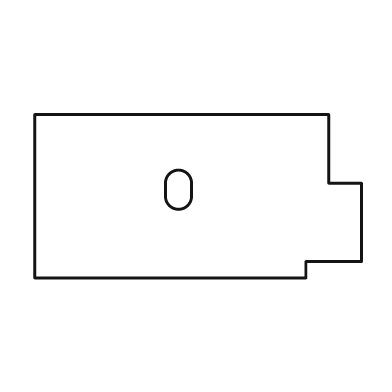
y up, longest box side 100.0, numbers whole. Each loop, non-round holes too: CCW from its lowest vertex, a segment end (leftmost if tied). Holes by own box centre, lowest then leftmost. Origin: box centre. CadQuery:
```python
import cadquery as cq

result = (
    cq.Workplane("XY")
    .moveTo(-50.0, -25.0)
    .lineTo(33.0, -25.0)
    .lineTo(33.0, -20.0)
    .lineTo(50.0, -20.0)
    .lineTo(50.0, 4.0)
    .lineTo(40.0, 4.0)
    .lineTo(40.0, 25.0)
    .lineTo(-50.0, 25.0)
    .close()
    .moveTo(-10.0, 0.0)
    .threePointArc((-6.0, -4.0), (-2.0, 0.0))
    .lineTo(-2.0, 4.0)
    .threePointArc((-6.0, 8.0), (-10.0, 4.0))
    .close()
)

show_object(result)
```